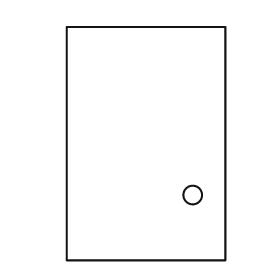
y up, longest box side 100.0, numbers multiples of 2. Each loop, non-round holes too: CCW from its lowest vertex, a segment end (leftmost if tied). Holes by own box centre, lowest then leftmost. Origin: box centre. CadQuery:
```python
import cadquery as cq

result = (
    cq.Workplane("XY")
    .moveTo(-34.0, -50.0)
    .lineTo(34.0, -50.0)
    .lineTo(34.0, 50.0)
    .lineTo(-34.0, 50.0)
    .close()
    .moveTo(20.0, -22.0)
    .circle(4.0)
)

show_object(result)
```